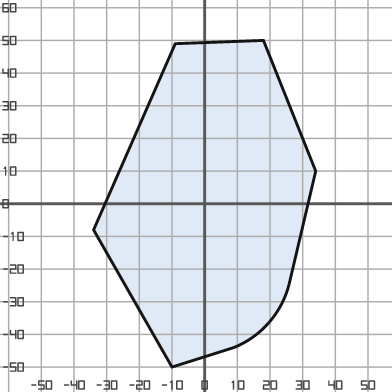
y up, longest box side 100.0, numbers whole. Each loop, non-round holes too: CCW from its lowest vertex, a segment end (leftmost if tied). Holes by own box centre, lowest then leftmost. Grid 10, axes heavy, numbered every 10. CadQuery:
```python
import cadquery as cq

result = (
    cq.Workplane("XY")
    .moveTo(-10.0, -50.0)
    .lineTo(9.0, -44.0)
    .threePointArc((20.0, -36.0), (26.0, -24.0))
    .lineTo(34.0, 10.0)
    .lineTo(18.0, 50.0)
    .lineTo(-9.0, 49.0)
    .lineTo(-34.0, -8.0)
    .close()
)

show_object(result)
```